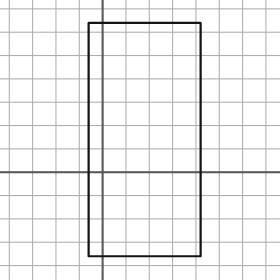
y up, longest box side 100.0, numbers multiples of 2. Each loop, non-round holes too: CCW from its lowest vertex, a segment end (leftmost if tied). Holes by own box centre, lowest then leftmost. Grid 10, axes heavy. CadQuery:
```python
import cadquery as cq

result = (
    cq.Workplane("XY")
    .moveTo(-6.0, -36.0)
    .lineTo(42.0, -36.0)
    .lineTo(42.0, 64.0)
    .lineTo(-6.0, 64.0)
    .close()
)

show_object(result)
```